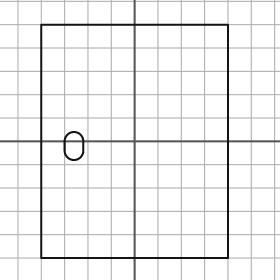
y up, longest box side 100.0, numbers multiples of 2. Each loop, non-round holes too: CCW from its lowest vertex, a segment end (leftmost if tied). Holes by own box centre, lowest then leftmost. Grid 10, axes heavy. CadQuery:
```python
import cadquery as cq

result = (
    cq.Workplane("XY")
    .moveTo(-40.0, -50.0)
    .lineTo(40.0, -50.0)
    .lineTo(40.0, 50.0)
    .lineTo(-40.0, 50.0)
    .close()
    .moveTo(-30.0, -4.0)
    .threePointArc((-26.0, -8.0), (-22.0, -4.0))
    .lineTo(-22.0, 0.0)
    .threePointArc((-26.0, 4.0), (-30.0, 0.0))
    .close()
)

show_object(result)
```